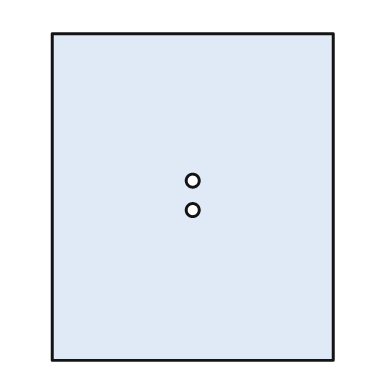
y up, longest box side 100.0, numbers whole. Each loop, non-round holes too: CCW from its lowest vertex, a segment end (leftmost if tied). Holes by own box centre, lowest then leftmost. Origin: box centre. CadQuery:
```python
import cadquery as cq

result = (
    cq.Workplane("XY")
    .moveTo(-43.0, -50.0)
    .lineTo(43.0, -50.0)
    .lineTo(43.0, 50.0)
    .lineTo(-43.0, 50.0)
    .close()
    .moveTo(0.0, -4.0)
    .circle(2.0)
    .moveTo(0.0, 5.0)
    .circle(2.0)
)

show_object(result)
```